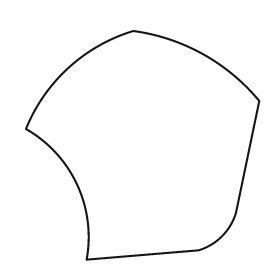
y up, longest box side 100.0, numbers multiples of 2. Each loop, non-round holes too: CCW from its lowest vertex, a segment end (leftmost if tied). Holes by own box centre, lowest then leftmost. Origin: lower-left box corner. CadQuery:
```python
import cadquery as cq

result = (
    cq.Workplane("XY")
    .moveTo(26.0, 0.0)
    .lineTo(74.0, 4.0)
    .threePointArc((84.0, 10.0), (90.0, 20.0))
    .lineTo(100.0, 68.0)
    .threePointArc((76.0, 88.0), (46.0, 98.0))
    .threePointArc((18.0, 82.0), (0.0, 56.0))
    .threePointArc((22.0, 32.0), (26.0, 0.0))
    .close()
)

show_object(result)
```